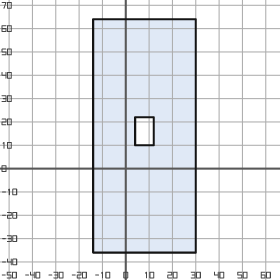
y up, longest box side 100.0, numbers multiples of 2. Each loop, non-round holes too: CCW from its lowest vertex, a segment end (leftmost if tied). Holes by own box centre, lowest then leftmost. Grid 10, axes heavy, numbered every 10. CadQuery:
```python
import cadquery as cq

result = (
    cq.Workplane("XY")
    .moveTo(-14.0, -36.0)
    .lineTo(30.0, -36.0)
    .lineTo(30.0, 64.0)
    .lineTo(-14.0, 64.0)
    .close()
    .moveTo(4.0, 10.0)
    .lineTo(12.0, 10.0)
    .lineTo(12.0, 22.0)
    .lineTo(4.0, 22.0)
    .close()
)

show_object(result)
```